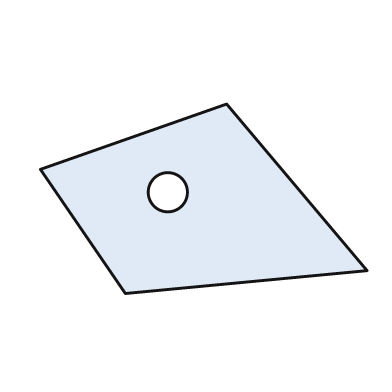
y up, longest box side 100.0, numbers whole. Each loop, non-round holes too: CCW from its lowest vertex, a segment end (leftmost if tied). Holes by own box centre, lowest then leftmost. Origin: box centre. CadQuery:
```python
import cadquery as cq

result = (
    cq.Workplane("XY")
    .moveTo(-24.0, -29.0)
    .lineTo(50.0, -22.0)
    .lineTo(7.0, 29.0)
    .lineTo(-50.0, 9.0)
    .close()
    .moveTo(-11.0, 2.0)
    .circle(6.0)
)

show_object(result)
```